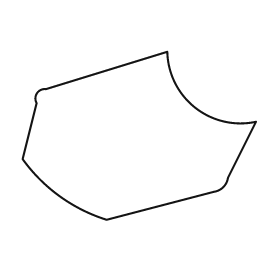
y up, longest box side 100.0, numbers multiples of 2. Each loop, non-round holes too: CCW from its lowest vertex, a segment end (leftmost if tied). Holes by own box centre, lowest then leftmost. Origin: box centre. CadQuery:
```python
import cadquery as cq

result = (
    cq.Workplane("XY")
    .moveTo(-14.0, -36.0)
    .lineTo(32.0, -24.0)
    .threePointArc((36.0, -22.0), (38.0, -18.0))
    .lineTo(50.0, 6.0)
    .threePointArc((24.0, 12.0), (12.0, 36.0))
    .lineTo(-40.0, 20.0)
    .threePointArc((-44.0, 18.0), (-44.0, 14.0))
    .lineTo(-50.0, -10.0)
    .threePointArc((-34.0, -26.0), (-14.0, -36.0))
    .close()
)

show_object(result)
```